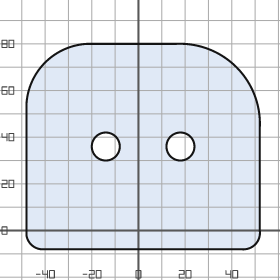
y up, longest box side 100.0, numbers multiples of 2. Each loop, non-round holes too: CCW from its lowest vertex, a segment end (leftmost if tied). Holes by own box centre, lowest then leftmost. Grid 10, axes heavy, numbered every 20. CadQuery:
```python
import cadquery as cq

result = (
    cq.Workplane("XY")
    .moveTo(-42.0, -8.0)
    .lineTo(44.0, -8.0)
    .threePointArc((50.0, -6.0), (52.0, 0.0))
    .lineTo(52.0, 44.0)
    .threePointArc((42.0, 70.0), (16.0, 80.0))
    .lineTo(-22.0, 80.0)
    .threePointArc((-40.0, 72.0), (-48.0, 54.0))
    .lineTo(-48.0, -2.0)
    .threePointArc((-46.0, -6.0), (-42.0, -8.0))
    .close()
    .moveTo(-14.0, 36.0)
    .circle(6.0)
    .moveTo(18.0, 36.0)
    .circle(6.0)
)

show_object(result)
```